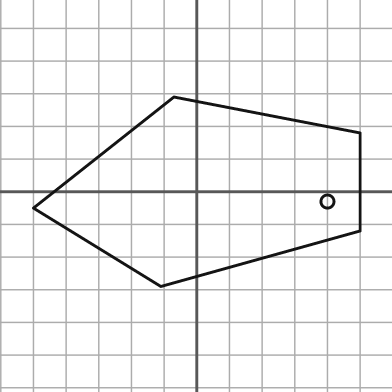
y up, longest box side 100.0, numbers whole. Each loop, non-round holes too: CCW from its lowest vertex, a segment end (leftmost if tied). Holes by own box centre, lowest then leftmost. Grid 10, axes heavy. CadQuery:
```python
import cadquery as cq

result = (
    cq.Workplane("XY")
    .moveTo(-11.0, -29.0)
    .lineTo(50.0, -12.0)
    .lineTo(50.0, 18.0)
    .lineTo(-7.0, 29.0)
    .lineTo(-50.0, -5.0)
    .close()
    .moveTo(40.0, -3.0)
    .circle(2.0)
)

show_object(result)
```